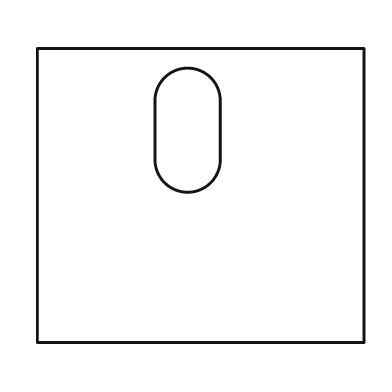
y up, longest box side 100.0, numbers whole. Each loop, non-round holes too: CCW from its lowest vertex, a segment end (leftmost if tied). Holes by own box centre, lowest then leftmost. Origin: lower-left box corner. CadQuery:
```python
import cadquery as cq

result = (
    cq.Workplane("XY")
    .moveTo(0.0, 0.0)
    .lineTo(100.0, 0.0)
    .lineTo(100.0, 90.0)
    .lineTo(0.0, 90.0)
    .close()
    .moveTo(36.0, 56.0)
    .threePointArc((46.0, 46.0), (56.0, 56.0))
    .lineTo(56.0, 74.0)
    .threePointArc((46.0, 84.0), (36.0, 74.0))
    .close()
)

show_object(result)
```